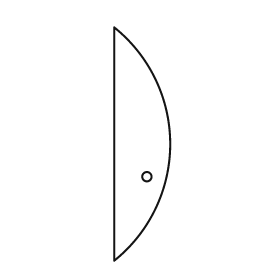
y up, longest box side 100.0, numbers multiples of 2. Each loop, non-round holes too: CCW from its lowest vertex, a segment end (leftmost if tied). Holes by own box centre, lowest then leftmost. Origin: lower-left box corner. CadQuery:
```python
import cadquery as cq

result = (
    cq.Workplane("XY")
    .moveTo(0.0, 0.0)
    .threePointArc((24.0, 50.0), (0.0, 100.0))
    .close()
    .moveTo(14.0, 36.0)
    .circle(2.0)
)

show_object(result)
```